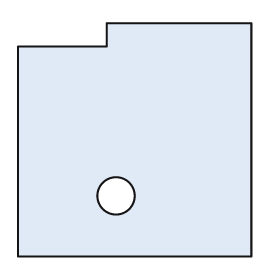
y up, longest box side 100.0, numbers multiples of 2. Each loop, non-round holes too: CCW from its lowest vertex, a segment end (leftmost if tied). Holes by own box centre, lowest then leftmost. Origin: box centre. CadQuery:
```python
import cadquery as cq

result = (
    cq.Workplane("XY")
    .moveTo(-50.0, -50.0)
    .lineTo(50.0, -50.0)
    .lineTo(50.0, 50.0)
    .lineTo(-12.0, 50.0)
    .lineTo(-12.0, 40.0)
    .lineTo(-50.0, 40.0)
    .close()
    .moveTo(-8.0, -24.0)
    .circle(8.0)
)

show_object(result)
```